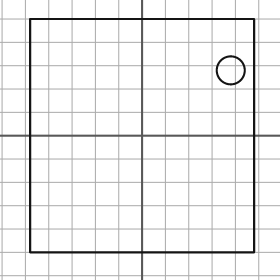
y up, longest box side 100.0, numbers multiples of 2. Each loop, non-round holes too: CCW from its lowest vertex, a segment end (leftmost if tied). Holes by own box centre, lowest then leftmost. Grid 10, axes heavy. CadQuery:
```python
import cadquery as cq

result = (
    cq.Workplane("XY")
    .moveTo(-48.0, -50.0)
    .lineTo(48.0, -50.0)
    .lineTo(48.0, 50.0)
    .lineTo(-48.0, 50.0)
    .close()
    .moveTo(38.0, 28.0)
    .circle(6.0)
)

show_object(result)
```